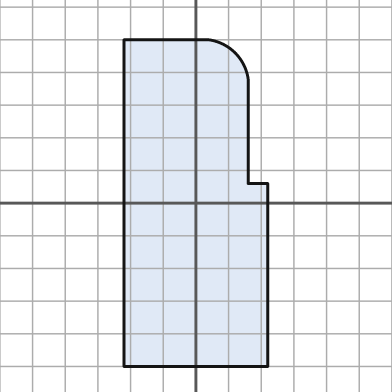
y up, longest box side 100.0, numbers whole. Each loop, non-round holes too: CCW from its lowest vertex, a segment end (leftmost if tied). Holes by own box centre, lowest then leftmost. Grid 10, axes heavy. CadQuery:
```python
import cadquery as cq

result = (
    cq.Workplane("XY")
    .moveTo(-22.0, -50.0)
    .lineTo(22.0, -50.0)
    .lineTo(22.0, 6.0)
    .lineTo(16.0, 6.0)
    .lineTo(16.0, 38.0)
    .threePointArc((12.0, 46.0), (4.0, 50.0))
    .lineTo(-22.0, 50.0)
    .close()
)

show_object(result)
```